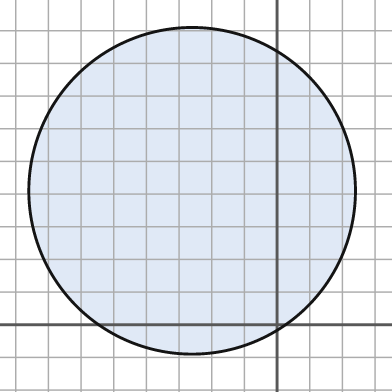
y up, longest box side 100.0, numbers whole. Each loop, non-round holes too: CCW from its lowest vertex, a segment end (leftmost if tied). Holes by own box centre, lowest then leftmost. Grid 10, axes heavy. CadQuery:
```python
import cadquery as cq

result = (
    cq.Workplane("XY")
    .moveTo(-26.0, 41.0)
    .circle(50.0)
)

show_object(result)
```